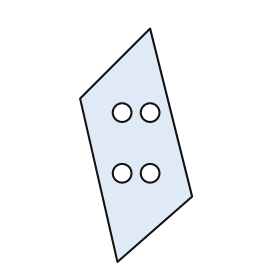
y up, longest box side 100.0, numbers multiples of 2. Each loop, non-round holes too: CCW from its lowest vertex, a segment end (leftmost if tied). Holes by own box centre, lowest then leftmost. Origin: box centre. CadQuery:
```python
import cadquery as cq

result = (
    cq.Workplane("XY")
    .moveTo(-8.0, -50.0)
    .lineTo(24.0, -22.0)
    .lineTo(6.0, 50.0)
    .lineTo(-24.0, 20.0)
    .close()
    .moveTo(-6.0, -12.0)
    .circle(4.0)
    .moveTo(6.0, -12.0)
    .circle(4.0)
    .moveTo(-6.0, 14.0)
    .circle(4.0)
    .moveTo(6.0, 14.0)
    .circle(4.0)
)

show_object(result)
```